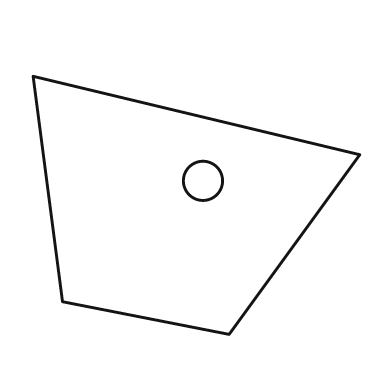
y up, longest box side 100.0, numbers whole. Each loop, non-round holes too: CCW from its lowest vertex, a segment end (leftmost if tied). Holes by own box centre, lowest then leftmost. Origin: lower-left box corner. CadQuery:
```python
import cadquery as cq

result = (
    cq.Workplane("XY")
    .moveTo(60.0, 0.0)
    .lineTo(100.0, 55.0)
    .lineTo(0.0, 79.0)
    .lineTo(9.0, 10.0)
    .close()
    .moveTo(52.0, 47.0)
    .circle(6.0)
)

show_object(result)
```